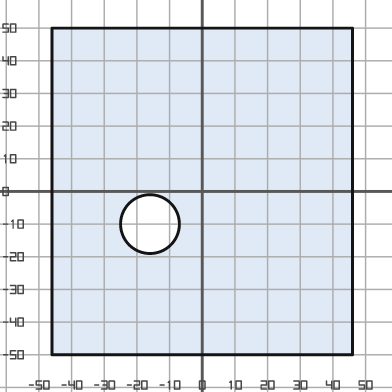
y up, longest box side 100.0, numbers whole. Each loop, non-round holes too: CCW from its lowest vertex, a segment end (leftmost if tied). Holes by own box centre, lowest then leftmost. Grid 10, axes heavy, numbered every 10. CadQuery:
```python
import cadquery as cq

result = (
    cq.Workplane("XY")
    .moveTo(-46.0, -50.0)
    .lineTo(46.0, -50.0)
    .lineTo(46.0, 50.0)
    .lineTo(-46.0, 50.0)
    .close()
    .moveTo(-16.0, -10.0)
    .circle(9.0)
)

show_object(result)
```